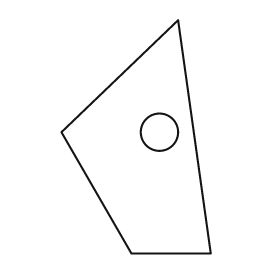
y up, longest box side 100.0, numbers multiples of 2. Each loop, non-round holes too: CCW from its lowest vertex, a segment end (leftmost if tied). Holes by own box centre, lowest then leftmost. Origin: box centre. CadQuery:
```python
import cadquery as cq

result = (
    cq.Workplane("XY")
    .moveTo(-2.0, -50.0)
    .lineTo(32.0, -50.0)
    .lineTo(18.0, 50.0)
    .lineTo(-32.0, 2.0)
    .close()
    .moveTo(10.0, 2.0)
    .circle(8.0)
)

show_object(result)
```